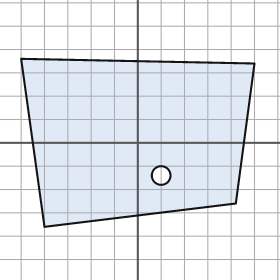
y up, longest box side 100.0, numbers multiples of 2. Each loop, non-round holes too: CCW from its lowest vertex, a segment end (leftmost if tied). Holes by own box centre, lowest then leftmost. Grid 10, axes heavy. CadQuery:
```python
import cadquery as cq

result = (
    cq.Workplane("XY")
    .moveTo(-40.0, -36.0)
    .lineTo(42.0, -26.0)
    .lineTo(50.0, 34.0)
    .lineTo(-50.0, 36.0)
    .close()
    .moveTo(10.0, -14.0)
    .circle(4.0)
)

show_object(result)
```